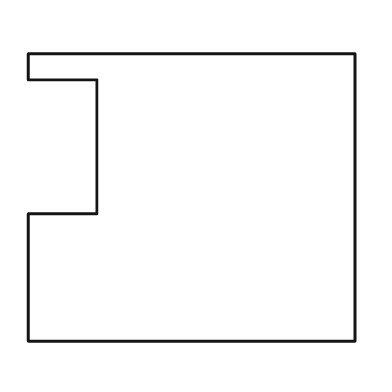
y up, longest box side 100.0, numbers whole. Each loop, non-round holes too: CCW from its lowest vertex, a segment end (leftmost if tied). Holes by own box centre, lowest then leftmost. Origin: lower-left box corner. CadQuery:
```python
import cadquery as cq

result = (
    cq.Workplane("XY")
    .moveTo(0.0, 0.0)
    .lineTo(100.0, 0.0)
    .lineTo(100.0, 88.0)
    .lineTo(0.0, 88.0)
    .lineTo(0.0, 80.0)
    .lineTo(21.0, 80.0)
    .lineTo(21.0, 39.0)
    .lineTo(0.0, 39.0)
    .close()
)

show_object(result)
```